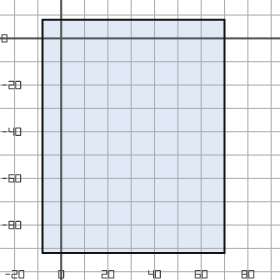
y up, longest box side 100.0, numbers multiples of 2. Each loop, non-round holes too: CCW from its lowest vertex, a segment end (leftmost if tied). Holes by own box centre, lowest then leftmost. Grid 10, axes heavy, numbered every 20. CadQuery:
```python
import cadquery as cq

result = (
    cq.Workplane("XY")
    .moveTo(-8.0, -92.0)
    .lineTo(70.0, -92.0)
    .lineTo(70.0, 8.0)
    .lineTo(-8.0, 8.0)
    .close()
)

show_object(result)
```